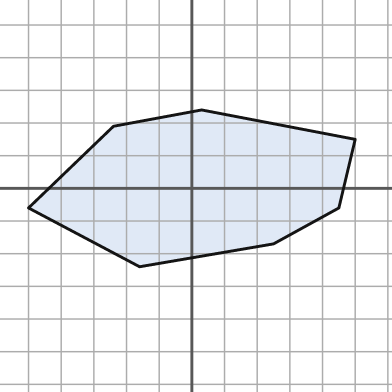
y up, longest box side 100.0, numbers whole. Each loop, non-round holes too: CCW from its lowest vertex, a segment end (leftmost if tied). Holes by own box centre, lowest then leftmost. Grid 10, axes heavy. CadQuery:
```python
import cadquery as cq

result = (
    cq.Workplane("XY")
    .moveTo(-16.0, -24.0)
    .lineTo(25.0, -17.0)
    .lineTo(45.0, -6.0)
    .lineTo(50.0, 15.0)
    .lineTo(3.0, 24.0)
    .lineTo(-24.0, 19.0)
    .lineTo(-50.0, -6.0)
    .close()
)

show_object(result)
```